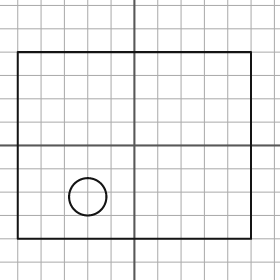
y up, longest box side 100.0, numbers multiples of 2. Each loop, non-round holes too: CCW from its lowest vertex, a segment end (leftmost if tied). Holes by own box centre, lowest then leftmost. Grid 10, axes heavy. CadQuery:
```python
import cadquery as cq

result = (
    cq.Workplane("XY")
    .moveTo(-50.0, -40.0)
    .lineTo(50.0, -40.0)
    .lineTo(50.0, 40.0)
    .lineTo(-50.0, 40.0)
    .close()
    .moveTo(-20.0, -22.0)
    .circle(8.0)
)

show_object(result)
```